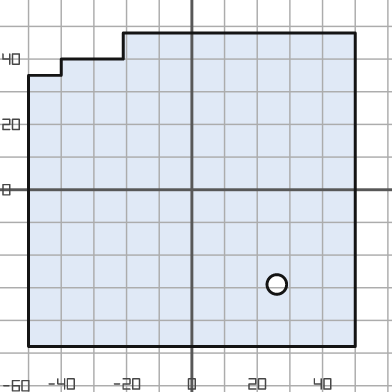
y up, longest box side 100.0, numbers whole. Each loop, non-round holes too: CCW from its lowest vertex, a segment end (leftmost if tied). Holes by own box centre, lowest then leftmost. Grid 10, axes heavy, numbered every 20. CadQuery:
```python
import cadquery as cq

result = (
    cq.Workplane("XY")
    .moveTo(-50.0, -48.0)
    .lineTo(50.0, -48.0)
    .lineTo(50.0, 48.0)
    .lineTo(-21.0, 48.0)
    .lineTo(-21.0, 40.0)
    .lineTo(-40.0, 40.0)
    .lineTo(-40.0, 35.0)
    .lineTo(-50.0, 35.0)
    .close()
    .moveTo(26.0, -29.0)
    .circle(3.0)
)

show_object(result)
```